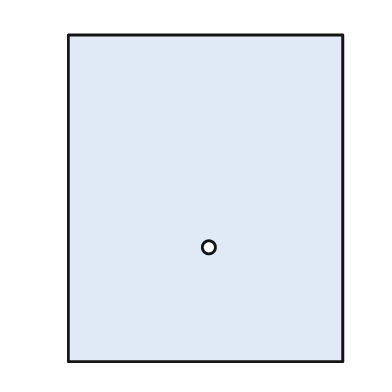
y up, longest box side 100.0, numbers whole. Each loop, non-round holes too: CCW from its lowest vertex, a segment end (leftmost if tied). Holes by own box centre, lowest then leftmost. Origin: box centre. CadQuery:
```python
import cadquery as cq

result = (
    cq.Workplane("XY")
    .moveTo(-42.0, -50.0)
    .lineTo(42.0, -50.0)
    .lineTo(42.0, 50.0)
    .lineTo(-42.0, 50.0)
    .close()
    .moveTo(1.0, -15.0)
    .circle(2.0)
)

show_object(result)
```